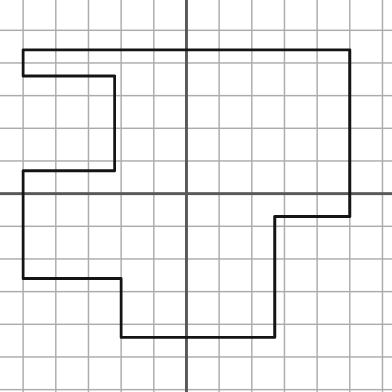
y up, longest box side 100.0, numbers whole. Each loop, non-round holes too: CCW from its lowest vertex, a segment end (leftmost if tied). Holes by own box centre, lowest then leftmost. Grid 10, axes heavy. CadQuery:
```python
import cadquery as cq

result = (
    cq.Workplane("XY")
    .moveTo(-20.0, -44.0)
    .lineTo(27.0, -44.0)
    .lineTo(27.0, -7.0)
    .lineTo(50.0, -7.0)
    .lineTo(50.0, 44.0)
    .lineTo(-50.0, 44.0)
    .lineTo(-50.0, 36.0)
    .lineTo(-22.0, 36.0)
    .lineTo(-22.0, 7.0)
    .lineTo(-50.0, 7.0)
    .lineTo(-50.0, -26.0)
    .lineTo(-20.0, -26.0)
    .close()
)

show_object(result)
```